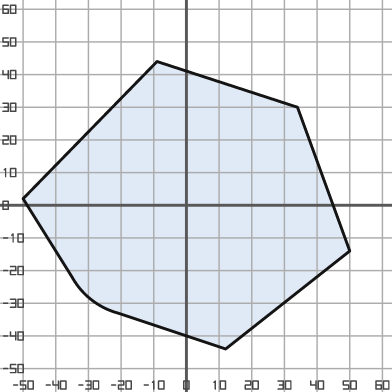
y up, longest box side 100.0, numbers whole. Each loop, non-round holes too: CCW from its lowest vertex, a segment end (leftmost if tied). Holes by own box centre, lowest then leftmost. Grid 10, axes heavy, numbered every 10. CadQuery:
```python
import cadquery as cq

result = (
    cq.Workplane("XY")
    .moveTo(12.0, -44.0)
    .lineTo(50.0, -14.0)
    .lineTo(34.0, 30.0)
    .lineTo(-9.0, 44.0)
    .lineTo(-50.0, 2.0)
    .lineTo(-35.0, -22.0)
    .threePointArc((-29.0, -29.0), (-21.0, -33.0))
    .close()
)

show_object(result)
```